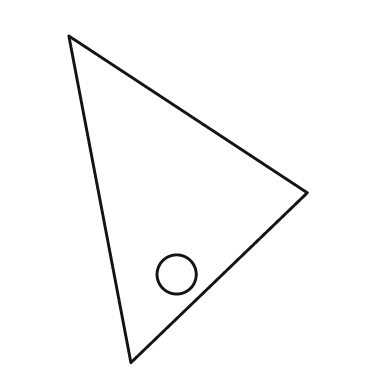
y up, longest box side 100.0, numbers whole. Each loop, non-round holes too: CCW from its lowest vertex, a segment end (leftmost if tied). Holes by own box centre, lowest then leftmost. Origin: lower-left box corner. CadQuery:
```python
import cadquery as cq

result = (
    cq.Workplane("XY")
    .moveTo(19.0, 0.0)
    .lineTo(73.0, 52.0)
    .lineTo(0.0, 100.0)
    .close()
    .moveTo(33.0, 27.0)
    .circle(6.0)
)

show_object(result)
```